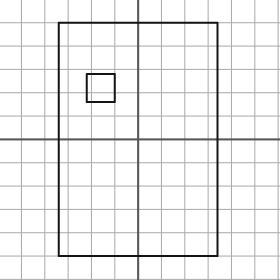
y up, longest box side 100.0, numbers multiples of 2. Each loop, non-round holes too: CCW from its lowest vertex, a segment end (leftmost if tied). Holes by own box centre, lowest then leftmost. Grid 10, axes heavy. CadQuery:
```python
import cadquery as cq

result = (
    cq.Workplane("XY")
    .moveTo(-34.0, -50.0)
    .lineTo(34.0, -50.0)
    .lineTo(34.0, 50.0)
    .lineTo(-34.0, 50.0)
    .close()
    .moveTo(-22.0, 16.0)
    .lineTo(-10.0, 16.0)
    .lineTo(-10.0, 28.0)
    .lineTo(-22.0, 28.0)
    .close()
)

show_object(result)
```